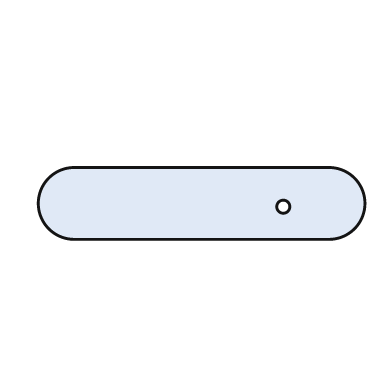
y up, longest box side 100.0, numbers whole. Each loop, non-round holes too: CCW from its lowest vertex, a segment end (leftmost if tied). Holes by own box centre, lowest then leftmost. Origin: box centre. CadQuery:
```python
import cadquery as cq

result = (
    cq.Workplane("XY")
    .moveTo(-39.0, -11.0)
    .lineTo(39.0, -11.0)
    .threePointArc((50.0, 0.0), (39.0, 11.0))
    .lineTo(-39.0, 11.0)
    .threePointArc((-50.0, 0.0), (-39.0, -11.0))
    .close()
    .moveTo(25.0, -1.0)
    .circle(2.0)
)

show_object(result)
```